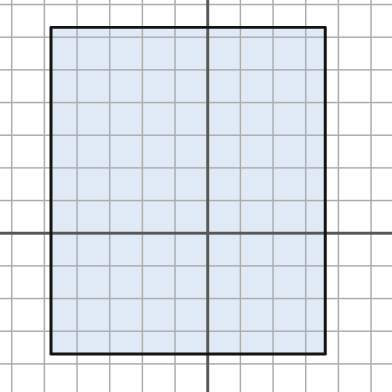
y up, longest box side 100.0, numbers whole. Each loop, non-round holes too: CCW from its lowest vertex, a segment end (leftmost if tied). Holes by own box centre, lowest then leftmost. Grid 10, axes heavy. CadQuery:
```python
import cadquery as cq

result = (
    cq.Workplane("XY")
    .moveTo(-48.0, -37.0)
    .lineTo(36.0, -37.0)
    .lineTo(36.0, 63.0)
    .lineTo(-48.0, 63.0)
    .close()
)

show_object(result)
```